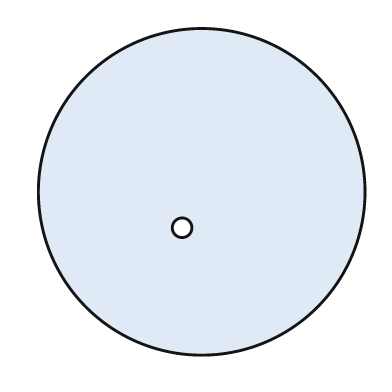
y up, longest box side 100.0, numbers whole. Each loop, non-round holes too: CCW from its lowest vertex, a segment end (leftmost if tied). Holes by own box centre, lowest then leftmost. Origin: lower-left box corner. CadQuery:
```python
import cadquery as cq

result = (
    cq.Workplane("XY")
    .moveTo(50.0, 50.0)
    .circle(50.0)
    .moveTo(44.0, 39.0)
    .circle(3.0)
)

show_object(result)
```